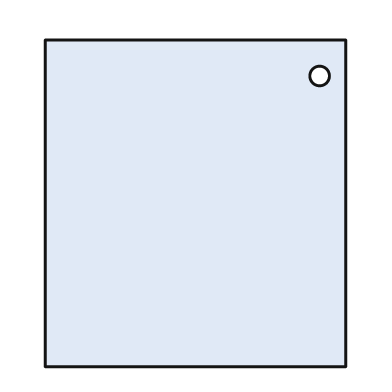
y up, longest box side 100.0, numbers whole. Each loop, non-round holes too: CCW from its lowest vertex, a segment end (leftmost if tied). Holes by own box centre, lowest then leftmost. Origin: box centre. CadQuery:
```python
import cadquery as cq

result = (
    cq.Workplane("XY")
    .moveTo(-46.0, -50.0)
    .lineTo(46.0, -50.0)
    .lineTo(46.0, 50.0)
    .lineTo(-46.0, 50.0)
    .close()
    .moveTo(38.0, 39.0)
    .circle(3.0)
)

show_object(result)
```